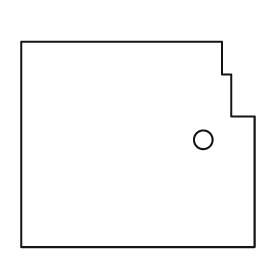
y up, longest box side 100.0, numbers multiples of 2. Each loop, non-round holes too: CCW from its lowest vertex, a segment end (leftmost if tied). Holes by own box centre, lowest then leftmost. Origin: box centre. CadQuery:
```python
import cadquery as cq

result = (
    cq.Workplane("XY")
    .moveTo(-50.0, -44.0)
    .lineTo(50.0, -44.0)
    .lineTo(50.0, 12.0)
    .lineTo(40.0, 12.0)
    .lineTo(40.0, 30.0)
    .lineTo(36.0, 30.0)
    .lineTo(36.0, 44.0)
    .lineTo(-50.0, 44.0)
    .close()
    .moveTo(28.0, 2.0)
    .circle(4.0)
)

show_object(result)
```